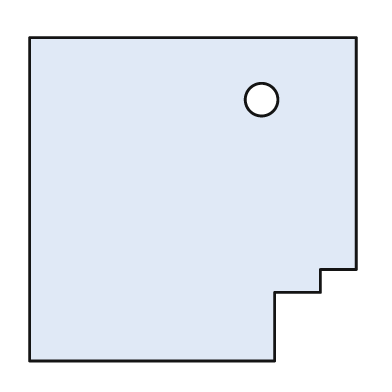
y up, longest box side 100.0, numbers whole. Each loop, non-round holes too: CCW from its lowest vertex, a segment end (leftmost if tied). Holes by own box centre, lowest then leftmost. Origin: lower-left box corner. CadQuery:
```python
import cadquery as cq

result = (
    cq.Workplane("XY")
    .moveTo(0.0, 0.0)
    .lineTo(75.0, 0.0)
    .lineTo(75.0, 21.0)
    .lineTo(89.0, 21.0)
    .lineTo(89.0, 28.0)
    .lineTo(100.0, 28.0)
    .lineTo(100.0, 99.0)
    .lineTo(0.0, 99.0)
    .close()
    .moveTo(71.0, 80.0)
    .circle(5.0)
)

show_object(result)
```